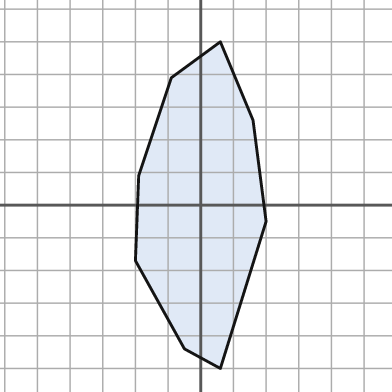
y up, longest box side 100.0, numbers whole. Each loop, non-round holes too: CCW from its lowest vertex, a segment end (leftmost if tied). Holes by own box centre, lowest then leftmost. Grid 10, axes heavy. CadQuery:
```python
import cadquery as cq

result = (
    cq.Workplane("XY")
    .moveTo(6.0, -50.0)
    .lineTo(20.0, -5.0)
    .lineTo(16.0, 26.0)
    .lineTo(6.0, 50.0)
    .lineTo(-9.0, 39.0)
    .lineTo(-19.0, 9.0)
    .lineTo(-20.0, -17.0)
    .lineTo(-5.0, -44.0)
    .close()
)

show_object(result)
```